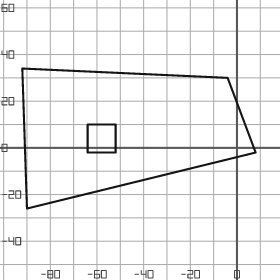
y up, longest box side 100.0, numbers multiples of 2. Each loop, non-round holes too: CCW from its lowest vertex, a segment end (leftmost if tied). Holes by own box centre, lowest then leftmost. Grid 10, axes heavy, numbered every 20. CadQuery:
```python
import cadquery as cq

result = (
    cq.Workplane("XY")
    .moveTo(-90.0, -26.0)
    .lineTo(8.0, -2.0)
    .lineTo(-4.0, 30.0)
    .lineTo(-92.0, 34.0)
    .close()
    .moveTo(-64.0, -2.0)
    .lineTo(-52.0, -2.0)
    .lineTo(-52.0, 10.0)
    .lineTo(-64.0, 10.0)
    .close()
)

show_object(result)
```